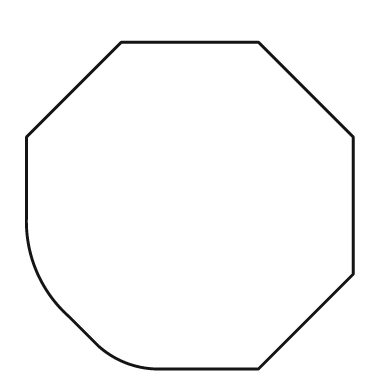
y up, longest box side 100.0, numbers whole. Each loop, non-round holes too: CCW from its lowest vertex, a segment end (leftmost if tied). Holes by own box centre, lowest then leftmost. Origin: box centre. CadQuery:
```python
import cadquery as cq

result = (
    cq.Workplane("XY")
    .moveTo(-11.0, -50.0)
    .lineTo(21.0, -50.0)
    .lineTo(50.0, -21.0)
    .lineTo(50.0, 21.0)
    .lineTo(21.0, 50.0)
    .lineTo(-21.0, 50.0)
    .lineTo(-50.0, 21.0)
    .lineTo(-50.0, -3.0)
    .threePointArc((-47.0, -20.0), (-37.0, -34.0))
    .lineTo(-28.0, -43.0)
    .threePointArc((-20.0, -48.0), (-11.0, -50.0))
    .close()
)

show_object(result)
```